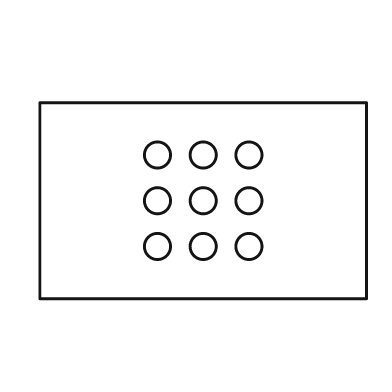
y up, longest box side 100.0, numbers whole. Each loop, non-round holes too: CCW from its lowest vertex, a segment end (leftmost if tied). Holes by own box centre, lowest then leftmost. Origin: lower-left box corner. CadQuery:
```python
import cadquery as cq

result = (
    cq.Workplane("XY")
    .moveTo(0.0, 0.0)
    .lineTo(100.0, 0.0)
    .lineTo(100.0, 60.0)
    .lineTo(0.0, 60.0)
    .close()
    .moveTo(36.0, 16.0)
    .circle(4.0)
    .moveTo(50.0, 16.0)
    .circle(4.0)
    .moveTo(64.0, 16.0)
    .circle(4.0)
    .moveTo(36.0, 30.0)
    .circle(4.0)
    .moveTo(50.0, 30.0)
    .circle(4.0)
    .moveTo(64.0, 30.0)
    .circle(4.0)
    .moveTo(36.0, 44.0)
    .circle(4.0)
    .moveTo(50.0, 44.0)
    .circle(4.0)
    .moveTo(64.0, 44.0)
    .circle(4.0)
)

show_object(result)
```